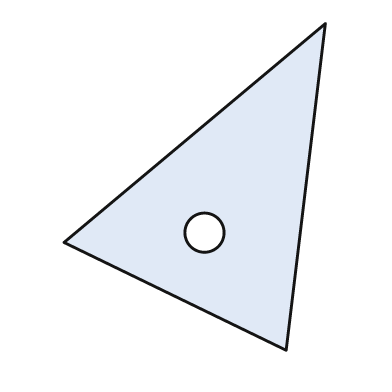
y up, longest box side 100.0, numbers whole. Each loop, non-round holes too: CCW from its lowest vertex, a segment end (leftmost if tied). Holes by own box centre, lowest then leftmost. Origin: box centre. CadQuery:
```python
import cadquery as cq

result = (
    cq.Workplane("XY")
    .moveTo(28.0, -50.0)
    .lineTo(40.0, 50.0)
    .lineTo(-40.0, -17.0)
    .close()
    .moveTo(3.0, -14.0)
    .circle(6.0)
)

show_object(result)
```